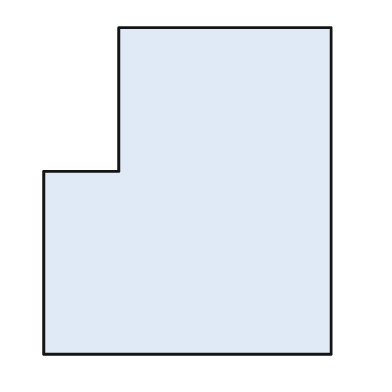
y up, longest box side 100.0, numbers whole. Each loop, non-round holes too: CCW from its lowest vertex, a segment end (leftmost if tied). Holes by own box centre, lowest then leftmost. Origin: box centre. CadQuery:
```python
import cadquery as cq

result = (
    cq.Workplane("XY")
    .moveTo(-44.0, -50.0)
    .lineTo(44.0, -50.0)
    .lineTo(44.0, 50.0)
    .lineTo(-21.0, 50.0)
    .lineTo(-21.0, 6.0)
    .lineTo(-44.0, 6.0)
    .close()
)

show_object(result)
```